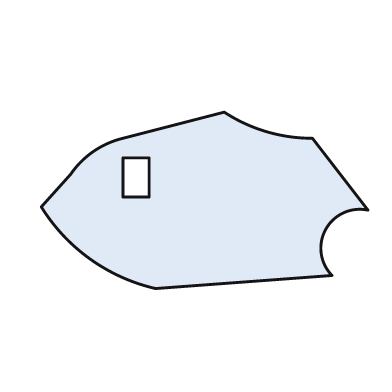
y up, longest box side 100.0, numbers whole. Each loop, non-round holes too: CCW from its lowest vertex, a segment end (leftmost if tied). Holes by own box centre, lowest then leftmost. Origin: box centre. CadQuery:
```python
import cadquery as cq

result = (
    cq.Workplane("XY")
    .moveTo(-15.0, -27.0)
    .lineTo(39.0, -23.0)
    .threePointArc((37.0, -9.0), (50.0, -3.0))
    .lineTo(33.0, 19.0)
    .threePointArc((19.0, 21.0), (6.0, 27.0))
    .lineTo(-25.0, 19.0)
    .threePointArc((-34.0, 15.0), (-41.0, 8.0))
    .lineTo(-50.0, -2.0)
    .threePointArc((-35.0, -18.0), (-15.0, -27.0))
    .close()
    .moveTo(-25.0, 1.0)
    .lineTo(-17.0, 1.0)
    .lineTo(-17.0, 13.0)
    .lineTo(-25.0, 13.0)
    .close()
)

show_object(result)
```